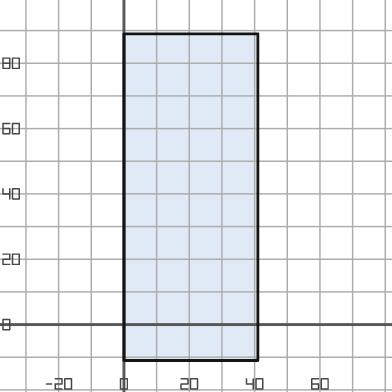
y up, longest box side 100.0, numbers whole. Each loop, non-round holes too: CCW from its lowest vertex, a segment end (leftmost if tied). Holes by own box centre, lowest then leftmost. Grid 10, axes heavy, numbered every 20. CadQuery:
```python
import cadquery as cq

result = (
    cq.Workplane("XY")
    .moveTo(0.0, -11.0)
    .lineTo(41.0, -11.0)
    .lineTo(41.0, 89.0)
    .lineTo(0.0, 89.0)
    .close()
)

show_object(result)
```